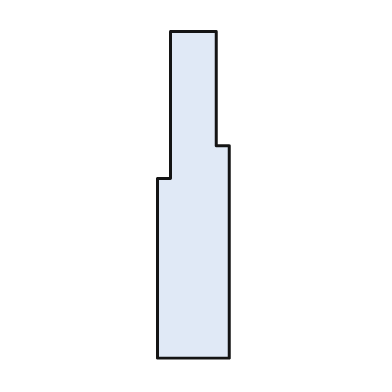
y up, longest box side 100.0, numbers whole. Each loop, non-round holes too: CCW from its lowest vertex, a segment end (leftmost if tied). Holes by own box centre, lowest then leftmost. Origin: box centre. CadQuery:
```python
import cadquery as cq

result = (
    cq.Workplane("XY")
    .moveTo(-11.0, -50.0)
    .lineTo(11.0, -50.0)
    .lineTo(11.0, 15.0)
    .lineTo(7.0, 15.0)
    .lineTo(7.0, 50.0)
    .lineTo(-7.0, 50.0)
    .lineTo(-7.0, 5.0)
    .lineTo(-11.0, 5.0)
    .close()
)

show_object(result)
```